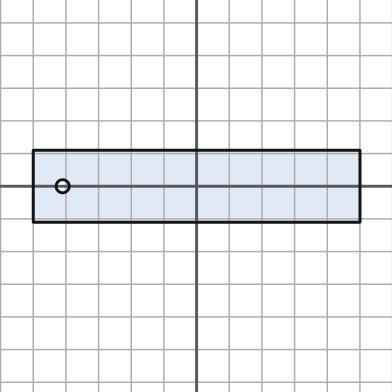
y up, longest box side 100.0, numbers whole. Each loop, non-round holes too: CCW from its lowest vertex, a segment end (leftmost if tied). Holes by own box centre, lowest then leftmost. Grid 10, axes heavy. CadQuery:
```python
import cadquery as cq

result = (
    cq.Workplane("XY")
    .moveTo(-50.0, -11.0)
    .lineTo(50.0, -11.0)
    .lineTo(50.0, 11.0)
    .lineTo(-50.0, 11.0)
    .close()
    .moveTo(-41.0, 0.0)
    .circle(2.0)
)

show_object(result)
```